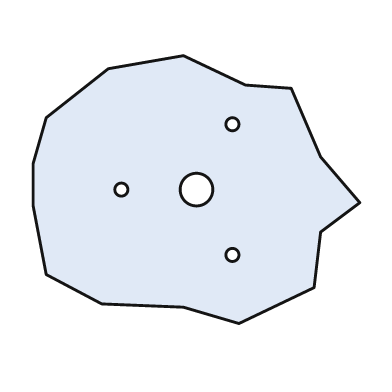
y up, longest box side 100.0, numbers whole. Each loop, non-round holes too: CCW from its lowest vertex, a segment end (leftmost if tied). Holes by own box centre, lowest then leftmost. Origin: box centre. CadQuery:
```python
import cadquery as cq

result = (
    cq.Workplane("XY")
    .moveTo(13.0, -41.0)
    .lineTo(36.0, -30.0)
    .lineTo(38.0, -13.0)
    .lineTo(50.0, -4.0)
    .lineTo(38.0, 10.0)
    .lineTo(29.0, 31.0)
    .lineTo(15.0, 32.0)
    .lineTo(-4.0, 41.0)
    .lineTo(-27.0, 37.0)
    .lineTo(-46.0, 22.0)
    .lineTo(-50.0, 8.0)
    .lineTo(-50.0, -5.0)
    .lineTo(-46.0, -26.0)
    .lineTo(-29.0, -35.0)
    .lineTo(-4.0, -36.0)
    .close()
    .moveTo(11.0, -20.0)
    .circle(2.0)
    .moveTo(-23.0, 0.0)
    .circle(2.0)
    .moveTo(0.0, 0.0)
    .circle(5.0)
    .moveTo(11.0, 20.0)
    .circle(2.0)
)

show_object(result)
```